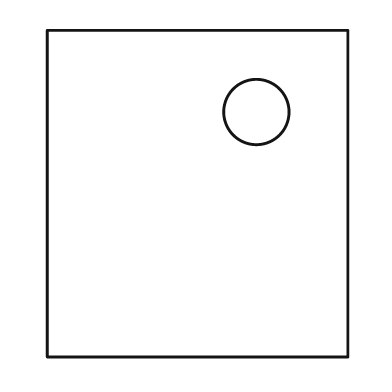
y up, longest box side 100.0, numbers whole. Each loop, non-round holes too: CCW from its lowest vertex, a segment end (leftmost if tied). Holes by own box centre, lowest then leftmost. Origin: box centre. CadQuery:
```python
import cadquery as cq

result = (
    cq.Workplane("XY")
    .moveTo(-46.0, -50.0)
    .lineTo(46.0, -50.0)
    .lineTo(46.0, 50.0)
    .lineTo(-46.0, 50.0)
    .close()
    .moveTo(18.0, 25.0)
    .circle(10.0)
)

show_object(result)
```